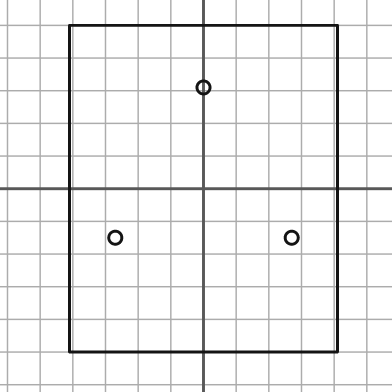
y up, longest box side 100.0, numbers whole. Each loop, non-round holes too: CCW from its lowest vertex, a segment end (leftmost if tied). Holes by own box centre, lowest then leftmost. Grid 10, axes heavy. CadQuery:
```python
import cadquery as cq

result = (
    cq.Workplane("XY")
    .moveTo(-41.0, -50.0)
    .lineTo(41.0, -50.0)
    .lineTo(41.0, 50.0)
    .lineTo(-41.0, 50.0)
    .close()
    .moveTo(-27.0, -15.0)
    .circle(2.0)
    .moveTo(27.0, -15.0)
    .circle(2.0)
    .moveTo(0.0, 31.0)
    .circle(2.0)
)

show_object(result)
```